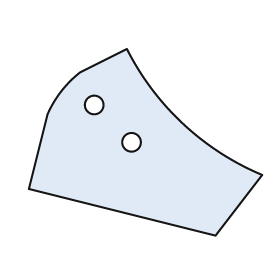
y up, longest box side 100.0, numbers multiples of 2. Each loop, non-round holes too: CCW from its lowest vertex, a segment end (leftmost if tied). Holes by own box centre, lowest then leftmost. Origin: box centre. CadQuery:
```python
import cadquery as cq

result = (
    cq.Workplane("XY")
    .moveTo(30.0, -40.0)
    .lineTo(50.0, -14.0)
    .threePointArc((16.0, 8.0), (-8.0, 40.0))
    .lineTo(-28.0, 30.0)
    .threePointArc((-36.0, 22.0), (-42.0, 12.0))
    .lineTo(-50.0, -20.0)
    .close()
    .moveTo(-6.0, 0.0)
    .circle(4.0)
    .moveTo(-22.0, 16.0)
    .circle(4.0)
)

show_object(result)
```